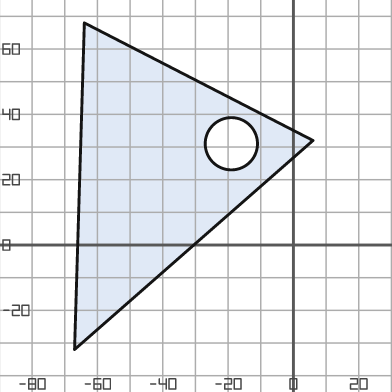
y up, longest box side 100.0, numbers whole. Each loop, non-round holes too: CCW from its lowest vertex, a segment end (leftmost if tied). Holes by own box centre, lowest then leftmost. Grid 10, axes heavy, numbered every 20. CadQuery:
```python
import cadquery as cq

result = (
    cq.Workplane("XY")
    .moveTo(-67.0, -32.0)
    .lineTo(6.0, 32.0)
    .lineTo(-64.0, 68.0)
    .close()
    .moveTo(-19.0, 31.0)
    .circle(8.0)
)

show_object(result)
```